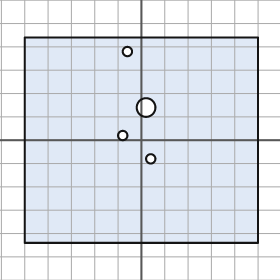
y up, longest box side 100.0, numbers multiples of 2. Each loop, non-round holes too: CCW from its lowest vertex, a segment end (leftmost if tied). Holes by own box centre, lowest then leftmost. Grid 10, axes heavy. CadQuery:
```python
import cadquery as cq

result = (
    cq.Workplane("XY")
    .moveTo(-50.0, -44.0)
    .lineTo(50.0, -44.0)
    .lineTo(50.0, 44.0)
    .lineTo(-50.0, 44.0)
    .close()
    .moveTo(4.0, -8.0)
    .circle(2.0)
    .moveTo(-8.0, 2.0)
    .circle(2.0)
    .moveTo(2.0, 14.0)
    .circle(4.0)
    .moveTo(-6.0, 38.0)
    .circle(2.0)
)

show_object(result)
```